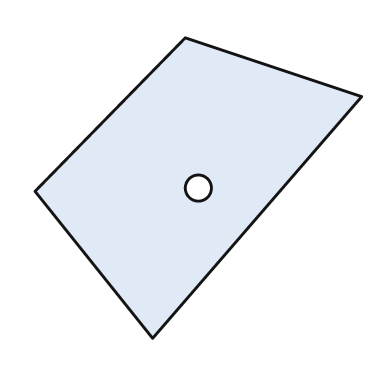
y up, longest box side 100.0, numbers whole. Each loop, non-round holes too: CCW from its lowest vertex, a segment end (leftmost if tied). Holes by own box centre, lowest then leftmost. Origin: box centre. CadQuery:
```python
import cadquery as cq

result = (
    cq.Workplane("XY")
    .moveTo(-14.0, -46.0)
    .lineTo(50.0, 28.0)
    .lineTo(-4.0, 46.0)
    .lineTo(-50.0, -1.0)
    .close()
    .moveTo(0.0, 0.0)
    .circle(4.0)
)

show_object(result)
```